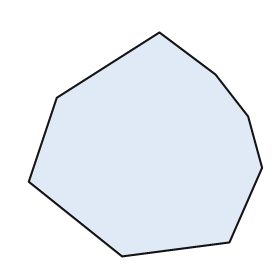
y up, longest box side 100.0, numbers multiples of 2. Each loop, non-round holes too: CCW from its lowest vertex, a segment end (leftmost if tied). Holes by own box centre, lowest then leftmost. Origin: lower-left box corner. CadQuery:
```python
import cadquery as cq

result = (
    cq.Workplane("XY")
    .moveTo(40.0, 0.0)
    .lineTo(86.0, 6.0)
    .lineTo(100.0, 38.0)
    .lineTo(94.0, 60.0)
    .lineTo(80.0, 78.0)
    .lineTo(56.0, 96.0)
    .lineTo(12.0, 68.0)
    .lineTo(0.0, 32.0)
    .close()
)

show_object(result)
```